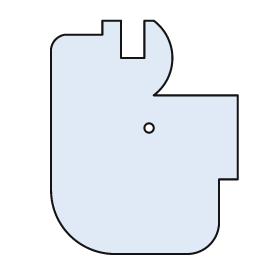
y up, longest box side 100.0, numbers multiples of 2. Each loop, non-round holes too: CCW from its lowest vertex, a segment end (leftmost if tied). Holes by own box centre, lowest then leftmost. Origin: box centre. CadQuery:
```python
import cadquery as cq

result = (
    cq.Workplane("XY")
    .moveTo(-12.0, -50.0)
    .lineTo(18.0, -50.0)
    .threePointArc((28.0, -46.0), (32.0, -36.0))
    .lineTo(32.0, -18.0)
    .lineTo(40.0, -18.0)
    .lineTo(40.0, 18.0)
    .lineTo(4.0, 18.0)
    .threePointArc((12.0, 34.0), (4.0, 50.0))
    .lineTo(0.0, 50.0)
    .lineTo(0.0, 34.0)
    .lineTo(-10.0, 34.0)
    .lineTo(-10.0, 50.0)
    .lineTo(-18.0, 50.0)
    .lineTo(-18.0, 44.0)
    .lineTo(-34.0, 44.0)
    .threePointArc((-38.0, 42.0), (-40.0, 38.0))
    .lineTo(-40.0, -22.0)
    .threePointArc((-32.0, -42.0), (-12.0, -50.0))
    .close()
    .moveTo(2.0, 4.0)
    .circle(2.0)
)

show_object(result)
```